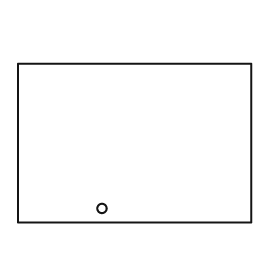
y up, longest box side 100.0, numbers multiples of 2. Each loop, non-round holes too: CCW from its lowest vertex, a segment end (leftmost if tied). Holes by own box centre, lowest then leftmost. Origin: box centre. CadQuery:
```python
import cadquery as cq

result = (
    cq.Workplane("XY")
    .moveTo(-50.0, -34.0)
    .lineTo(50.0, -34.0)
    .lineTo(50.0, 34.0)
    .lineTo(-50.0, 34.0)
    .close()
    .moveTo(-14.0, -28.0)
    .circle(2.0)
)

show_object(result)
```